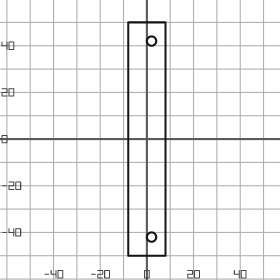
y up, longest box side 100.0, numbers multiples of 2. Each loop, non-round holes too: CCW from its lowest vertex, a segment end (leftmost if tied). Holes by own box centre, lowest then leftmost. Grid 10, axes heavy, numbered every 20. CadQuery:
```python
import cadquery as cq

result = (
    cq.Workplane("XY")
    .moveTo(-8.0, -50.0)
    .lineTo(8.0, -50.0)
    .lineTo(8.0, 50.0)
    .lineTo(-8.0, 50.0)
    .close()
    .moveTo(2.0, -42.0)
    .circle(2.0)
    .moveTo(2.0, 42.0)
    .circle(2.0)
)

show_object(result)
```